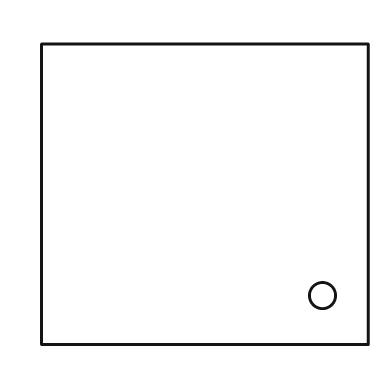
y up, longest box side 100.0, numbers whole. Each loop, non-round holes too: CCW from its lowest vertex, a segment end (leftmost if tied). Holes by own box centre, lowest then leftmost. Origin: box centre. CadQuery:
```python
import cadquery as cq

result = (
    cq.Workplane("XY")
    .moveTo(-50.0, -46.0)
    .lineTo(50.0, -46.0)
    .lineTo(50.0, 46.0)
    .lineTo(-50.0, 46.0)
    .close()
    .moveTo(36.0, -31.0)
    .circle(4.0)
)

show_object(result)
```